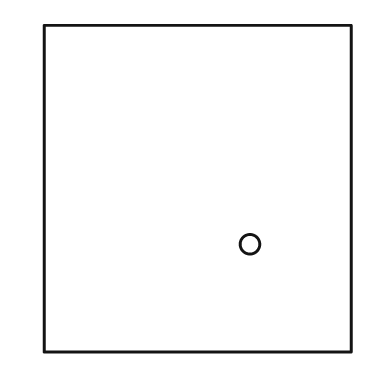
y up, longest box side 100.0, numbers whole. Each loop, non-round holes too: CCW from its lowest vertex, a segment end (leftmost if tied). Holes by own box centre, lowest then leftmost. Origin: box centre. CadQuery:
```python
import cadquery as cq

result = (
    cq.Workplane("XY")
    .moveTo(-47.0, -50.0)
    .lineTo(47.0, -50.0)
    .lineTo(47.0, 50.0)
    .lineTo(-47.0, 50.0)
    .close()
    .moveTo(16.0, -17.0)
    .circle(3.0)
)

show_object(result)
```